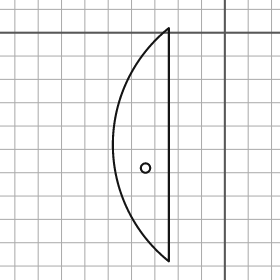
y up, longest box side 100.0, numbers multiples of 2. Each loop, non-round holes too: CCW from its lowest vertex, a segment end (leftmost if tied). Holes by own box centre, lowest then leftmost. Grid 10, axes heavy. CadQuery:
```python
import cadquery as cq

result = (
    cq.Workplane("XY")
    .moveTo(-24.0, -98.0)
    .lineTo(-24.0, 2.0)
    .threePointArc((-48.0, -48.0), (-24.0, -98.0))
    .close()
    .moveTo(-34.0, -58.0)
    .circle(2.0)
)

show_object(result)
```